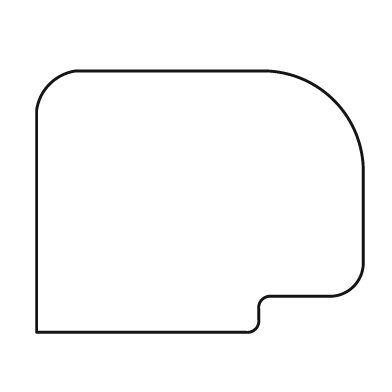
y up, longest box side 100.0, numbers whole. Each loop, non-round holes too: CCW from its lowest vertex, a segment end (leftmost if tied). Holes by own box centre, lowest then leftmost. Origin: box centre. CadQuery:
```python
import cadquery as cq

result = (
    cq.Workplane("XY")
    .moveTo(-50.0, -40.0)
    .lineTo(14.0, -40.0)
    .threePointArc((17.0, -39.0), (18.0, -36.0))
    .lineTo(18.0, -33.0)
    .threePointArc((19.0, -30.0), (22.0, -29.0))
    .lineTo(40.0, -29.0)
    .threePointArc((47.0, -26.0), (50.0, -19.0))
    .lineTo(50.0, 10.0)
    .threePointArc((41.0, 31.0), (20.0, 40.0))
    .lineTo(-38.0, 40.0)
    .threePointArc((-46.0, 36.0), (-50.0, 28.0))
    .close()
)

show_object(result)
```